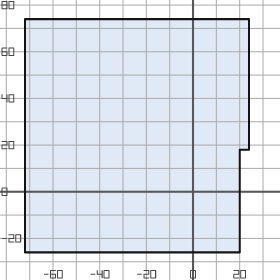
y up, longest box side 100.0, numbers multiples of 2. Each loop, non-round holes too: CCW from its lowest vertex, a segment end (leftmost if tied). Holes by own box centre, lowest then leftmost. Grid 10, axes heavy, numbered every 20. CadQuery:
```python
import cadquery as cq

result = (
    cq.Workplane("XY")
    .moveTo(-72.0, -26.0)
    .lineTo(20.0, -26.0)
    .lineTo(20.0, 18.0)
    .lineTo(24.0, 18.0)
    .lineTo(24.0, 74.0)
    .lineTo(-72.0, 74.0)
    .close()
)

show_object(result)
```